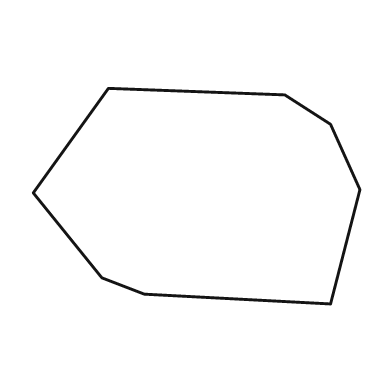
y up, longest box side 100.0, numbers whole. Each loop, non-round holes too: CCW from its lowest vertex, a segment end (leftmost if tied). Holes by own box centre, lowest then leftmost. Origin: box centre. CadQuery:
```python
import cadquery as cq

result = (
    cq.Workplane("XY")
    .moveTo(41.0, -33.0)
    .lineTo(50.0, 2.0)
    .lineTo(41.0, 22.0)
    .lineTo(27.0, 31.0)
    .lineTo(-27.0, 33.0)
    .lineTo(-50.0, 1.0)
    .lineTo(-29.0, -25.0)
    .lineTo(-16.0, -30.0)
    .close()
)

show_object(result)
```